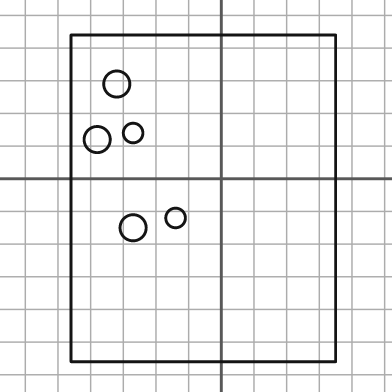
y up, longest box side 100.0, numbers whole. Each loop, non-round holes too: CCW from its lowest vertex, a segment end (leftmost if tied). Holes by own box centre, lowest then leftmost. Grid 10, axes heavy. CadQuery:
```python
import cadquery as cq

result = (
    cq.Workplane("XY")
    .moveTo(-46.0, -56.0)
    .lineTo(35.0, -56.0)
    .lineTo(35.0, 44.0)
    .lineTo(-46.0, 44.0)
    .close()
    .moveTo(-27.0, -15.0)
    .circle(4.0)
    .moveTo(-14.0, -12.0)
    .circle(3.0)
    .moveTo(-38.0, 12.0)
    .circle(4.0)
    .moveTo(-27.0, 14.0)
    .circle(3.0)
    .moveTo(-32.0, 29.0)
    .circle(4.0)
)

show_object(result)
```